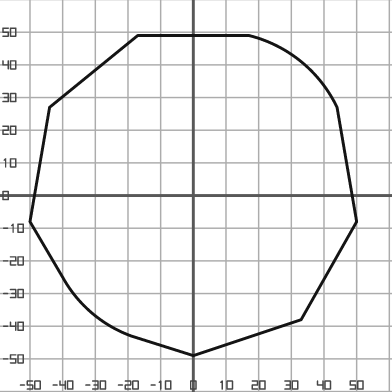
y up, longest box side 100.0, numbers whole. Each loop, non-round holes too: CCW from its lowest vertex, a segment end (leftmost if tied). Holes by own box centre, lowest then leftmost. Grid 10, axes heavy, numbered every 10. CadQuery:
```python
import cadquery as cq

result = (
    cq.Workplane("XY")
    .moveTo(0.0, -49.0)
    .lineTo(33.0, -38.0)
    .lineTo(50.0, -8.0)
    .lineTo(44.0, 27.0)
    .threePointArc((33.0, 41.0), (17.0, 49.0))
    .lineTo(-17.0, 49.0)
    .lineTo(-44.0, 27.0)
    .lineTo(-50.0, -8.0)
    .lineTo(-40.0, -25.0)
    .threePointArc((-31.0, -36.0), (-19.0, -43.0))
    .close()
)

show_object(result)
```